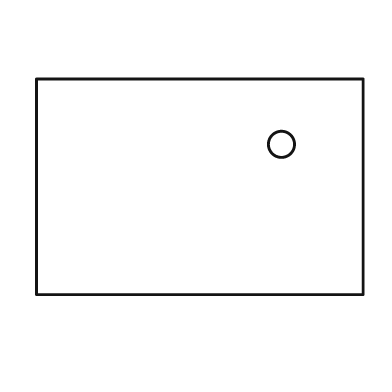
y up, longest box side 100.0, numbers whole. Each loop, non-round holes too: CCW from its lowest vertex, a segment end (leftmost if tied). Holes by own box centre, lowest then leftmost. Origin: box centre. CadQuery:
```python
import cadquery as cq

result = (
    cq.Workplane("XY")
    .moveTo(-50.0, -33.0)
    .lineTo(50.0, -33.0)
    .lineTo(50.0, 33.0)
    .lineTo(-50.0, 33.0)
    .close()
    .moveTo(25.0, 13.0)
    .circle(4.0)
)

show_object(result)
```